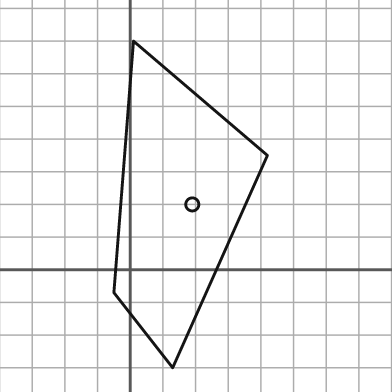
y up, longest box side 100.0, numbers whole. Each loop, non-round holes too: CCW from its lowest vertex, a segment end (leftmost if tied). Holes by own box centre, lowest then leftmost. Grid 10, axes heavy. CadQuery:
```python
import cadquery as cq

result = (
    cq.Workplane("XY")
    .moveTo(13.0, -30.0)
    .lineTo(42.0, 35.0)
    .lineTo(1.0, 70.0)
    .lineTo(-5.0, -7.0)
    .close()
    .moveTo(19.0, 20.0)
    .circle(2.0)
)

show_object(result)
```